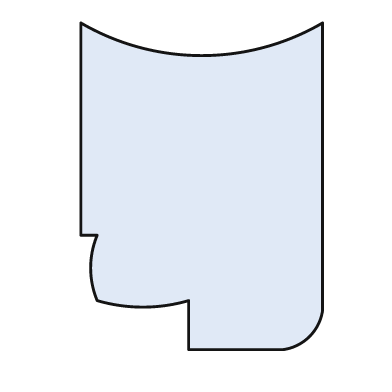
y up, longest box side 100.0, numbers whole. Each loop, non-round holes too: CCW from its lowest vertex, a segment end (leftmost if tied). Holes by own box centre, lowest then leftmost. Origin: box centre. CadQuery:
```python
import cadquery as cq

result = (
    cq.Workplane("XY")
    .moveTo(-4.0, -50.0)
    .lineTo(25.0, -50.0)
    .threePointArc((33.0, -46.0), (37.0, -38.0))
    .lineTo(37.0, 50.0)
    .threePointArc((0.0, 40.0), (-37.0, 50.0))
    .lineTo(-37.0, -15.0)
    .lineTo(-32.0, -15.0)
    .threePointArc((-34.0, -25.0), (-32.0, -35.0))
    .threePointArc((-18.0, -37.0), (-4.0, -35.0))
    .close()
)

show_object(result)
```